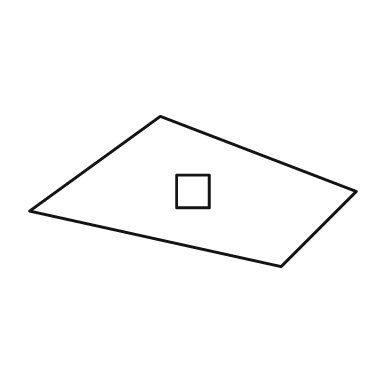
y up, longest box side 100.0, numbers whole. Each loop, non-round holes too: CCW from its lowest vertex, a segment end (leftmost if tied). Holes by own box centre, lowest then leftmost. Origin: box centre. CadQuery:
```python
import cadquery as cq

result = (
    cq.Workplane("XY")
    .moveTo(27.0, -23.0)
    .lineTo(50.0, 0.0)
    .lineTo(-10.0, 23.0)
    .lineTo(-50.0, -6.0)
    .close()
    .moveTo(-5.0, -5.0)
    .lineTo(5.0, -5.0)
    .lineTo(5.0, 5.0)
    .lineTo(-5.0, 5.0)
    .close()
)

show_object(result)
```